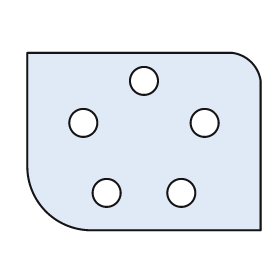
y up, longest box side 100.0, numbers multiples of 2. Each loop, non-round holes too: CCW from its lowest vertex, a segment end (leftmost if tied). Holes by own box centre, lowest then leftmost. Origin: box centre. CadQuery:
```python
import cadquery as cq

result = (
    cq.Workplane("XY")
    .moveTo(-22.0, -38.0)
    .lineTo(50.0, -38.0)
    .lineTo(50.0, 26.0)
    .threePointArc((46.0, 34.0), (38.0, 38.0))
    .lineTo(-50.0, 38.0)
    .lineTo(-50.0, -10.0)
    .threePointArc((-42.0, -30.0), (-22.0, -38.0))
    .close()
    .moveTo(-16.0, -22.0)
    .circle(6.0)
    .moveTo(16.0, -22.0)
    .circle(6.0)
    .moveTo(-26.0, 8.0)
    .circle(6.0)
    .moveTo(26.0, 8.0)
    .circle(6.0)
    .moveTo(0.0, 26.0)
    .circle(6.0)
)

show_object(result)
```